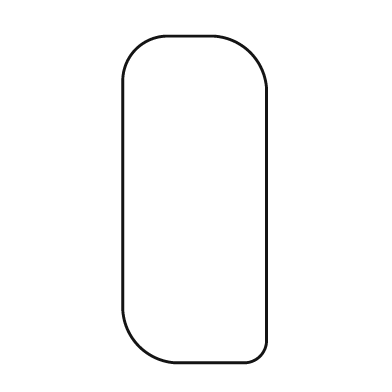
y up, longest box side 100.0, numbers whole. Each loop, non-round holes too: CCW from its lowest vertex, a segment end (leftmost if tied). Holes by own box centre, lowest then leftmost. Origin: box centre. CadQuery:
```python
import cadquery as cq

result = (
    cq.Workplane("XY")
    .moveTo(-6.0, -50.0)
    .lineTo(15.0, -50.0)
    .threePointArc((20.0, -48.0), (22.0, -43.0))
    .lineTo(22.0, 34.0)
    .threePointArc((17.0, 45.0), (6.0, 50.0))
    .lineTo(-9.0, 50.0)
    .threePointArc((-18.0, 46.0), (-22.0, 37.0))
    .lineTo(-22.0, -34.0)
    .threePointArc((-17.0, -45.0), (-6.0, -50.0))
    .close()
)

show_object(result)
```